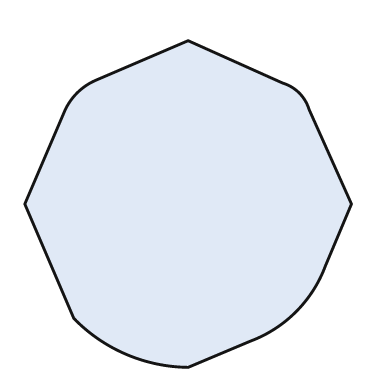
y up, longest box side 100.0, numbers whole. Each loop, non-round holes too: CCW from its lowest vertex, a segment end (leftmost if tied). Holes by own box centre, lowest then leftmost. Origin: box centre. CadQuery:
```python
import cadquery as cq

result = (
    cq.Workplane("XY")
    .moveTo(0.0, -50.0)
    .lineTo(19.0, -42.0)
    .threePointArc((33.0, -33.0), (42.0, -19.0))
    .lineTo(50.0, 0.0)
    .lineTo(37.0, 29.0)
    .threePointArc((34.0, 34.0), (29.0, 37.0))
    .lineTo(0.0, 50.0)
    .lineTo(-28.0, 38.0)
    .threePointArc((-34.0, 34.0), (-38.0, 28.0))
    .lineTo(-50.0, 0.0)
    .lineTo(-35.0, -35.0)
    .threePointArc((-19.0, -46.0), (0.0, -50.0))
    .close()
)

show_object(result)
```